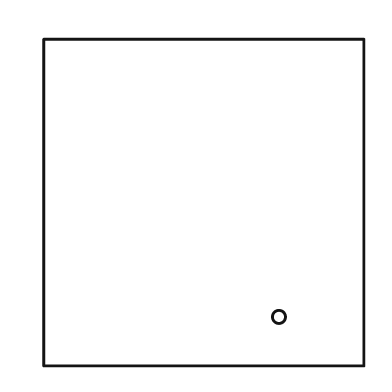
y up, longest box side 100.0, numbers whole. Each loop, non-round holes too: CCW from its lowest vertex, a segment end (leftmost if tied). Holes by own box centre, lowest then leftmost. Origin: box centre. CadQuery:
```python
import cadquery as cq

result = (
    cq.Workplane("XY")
    .moveTo(-49.0, -50.0)
    .lineTo(49.0, -50.0)
    .lineTo(49.0, 50.0)
    .lineTo(-49.0, 50.0)
    .close()
    .moveTo(23.0, -35.0)
    .circle(2.0)
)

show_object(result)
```